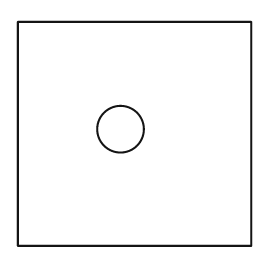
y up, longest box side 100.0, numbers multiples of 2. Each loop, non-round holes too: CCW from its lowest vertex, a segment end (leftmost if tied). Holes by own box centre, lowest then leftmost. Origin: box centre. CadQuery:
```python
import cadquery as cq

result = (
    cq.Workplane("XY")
    .moveTo(-50.0, -48.0)
    .lineTo(50.0, -48.0)
    .lineTo(50.0, 48.0)
    .lineTo(-50.0, 48.0)
    .close()
    .moveTo(-6.0, 2.0)
    .circle(10.0)
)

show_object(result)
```